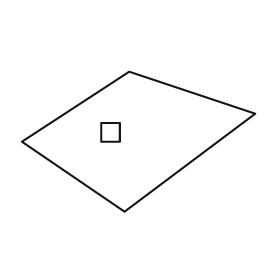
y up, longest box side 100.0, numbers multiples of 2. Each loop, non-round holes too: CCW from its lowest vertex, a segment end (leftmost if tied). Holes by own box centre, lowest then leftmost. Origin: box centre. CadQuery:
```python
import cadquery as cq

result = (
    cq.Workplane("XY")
    .moveTo(-6.0, -30.0)
    .lineTo(50.0, 12.0)
    .lineTo(-4.0, 30.0)
    .lineTo(-50.0, 0.0)
    .close()
    .moveTo(-16.0, 0.0)
    .lineTo(-8.0, 0.0)
    .lineTo(-8.0, 8.0)
    .lineTo(-16.0, 8.0)
    .close()
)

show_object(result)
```